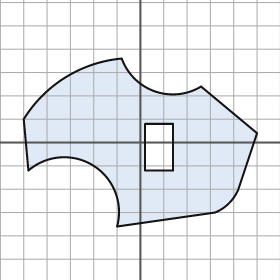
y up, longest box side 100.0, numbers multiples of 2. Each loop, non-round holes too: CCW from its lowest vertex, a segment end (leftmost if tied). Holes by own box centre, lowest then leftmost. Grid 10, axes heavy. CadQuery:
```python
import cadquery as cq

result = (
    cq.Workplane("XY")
    .moveTo(-10.0, -36.0)
    .lineTo(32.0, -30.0)
    .threePointArc((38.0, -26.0), (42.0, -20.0))
    .lineTo(50.0, 4.0)
    .lineTo(26.0, 24.0)
    .threePointArc((6.0, 22.0), (-8.0, 36.0))
    .threePointArc((-32.0, 28.0), (-50.0, 10.0))
    .lineTo(-48.0, -12.0)
    .threePointArc((-20.0, -10.0), (-10.0, -36.0))
    .close()
    .moveTo(2.0, -12.0)
    .lineTo(14.0, -12.0)
    .lineTo(14.0, 8.0)
    .lineTo(2.0, 8.0)
    .close()
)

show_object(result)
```